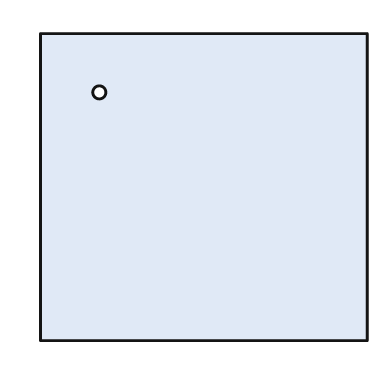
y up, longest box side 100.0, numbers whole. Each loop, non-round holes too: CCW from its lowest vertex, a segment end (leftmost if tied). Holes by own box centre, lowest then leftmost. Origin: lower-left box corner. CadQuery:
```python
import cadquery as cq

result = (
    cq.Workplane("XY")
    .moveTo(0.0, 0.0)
    .lineTo(100.0, 0.0)
    .lineTo(100.0, 94.0)
    .lineTo(0.0, 94.0)
    .close()
    .moveTo(18.0, 76.0)
    .circle(2.0)
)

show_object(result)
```